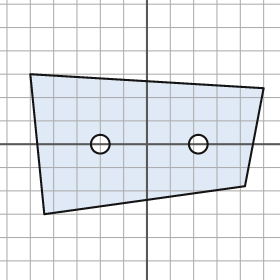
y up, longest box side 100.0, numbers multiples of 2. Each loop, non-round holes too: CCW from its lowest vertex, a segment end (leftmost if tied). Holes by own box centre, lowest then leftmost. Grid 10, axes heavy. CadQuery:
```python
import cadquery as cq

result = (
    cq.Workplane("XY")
    .moveTo(-44.0, -30.0)
    .lineTo(42.0, -18.0)
    .lineTo(50.0, 24.0)
    .lineTo(-50.0, 30.0)
    .close()
    .moveTo(-20.0, 0.0)
    .circle(4.0)
    .moveTo(22.0, 0.0)
    .circle(4.0)
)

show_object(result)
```